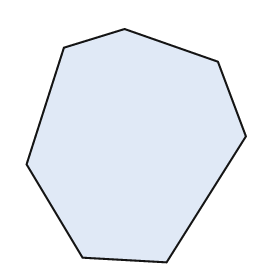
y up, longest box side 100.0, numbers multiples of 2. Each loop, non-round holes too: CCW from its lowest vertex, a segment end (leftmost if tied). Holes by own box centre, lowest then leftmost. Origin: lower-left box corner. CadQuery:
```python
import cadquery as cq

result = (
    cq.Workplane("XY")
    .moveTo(60.0, 0.0)
    .lineTo(94.0, 54.0)
    .lineTo(82.0, 86.0)
    .lineTo(42.0, 100.0)
    .lineTo(16.0, 92.0)
    .lineTo(0.0, 42.0)
    .lineTo(24.0, 2.0)
    .close()
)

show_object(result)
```